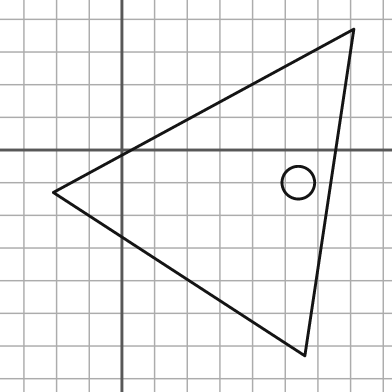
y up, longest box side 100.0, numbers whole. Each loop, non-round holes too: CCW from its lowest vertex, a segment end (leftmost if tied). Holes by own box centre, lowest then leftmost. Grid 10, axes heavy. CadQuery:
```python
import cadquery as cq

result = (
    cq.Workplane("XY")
    .moveTo(56.0, -63.0)
    .lineTo(71.0, 37.0)
    .lineTo(-21.0, -13.0)
    .close()
    .moveTo(54.0, -10.0)
    .circle(5.0)
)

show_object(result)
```